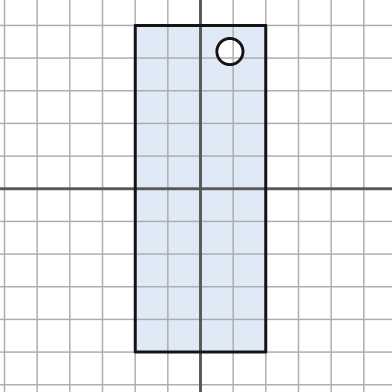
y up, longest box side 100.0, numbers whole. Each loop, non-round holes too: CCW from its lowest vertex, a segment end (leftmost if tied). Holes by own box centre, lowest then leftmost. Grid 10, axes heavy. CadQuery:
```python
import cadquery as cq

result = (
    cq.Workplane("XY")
    .moveTo(-20.0, -50.0)
    .lineTo(20.0, -50.0)
    .lineTo(20.0, 50.0)
    .lineTo(-20.0, 50.0)
    .close()
    .moveTo(9.0, 42.0)
    .circle(4.0)
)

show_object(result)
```